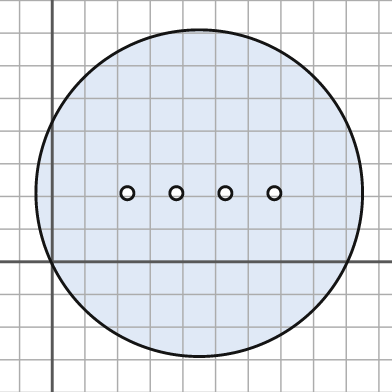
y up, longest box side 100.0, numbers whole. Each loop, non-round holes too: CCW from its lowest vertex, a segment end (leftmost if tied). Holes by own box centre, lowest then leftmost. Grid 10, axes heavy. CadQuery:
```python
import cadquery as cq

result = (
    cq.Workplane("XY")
    .moveTo(45.0, 21.0)
    .circle(50.0)
    .moveTo(23.0, 21.0)
    .circle(2.0)
    .moveTo(38.0, 21.0)
    .circle(2.0)
    .moveTo(53.0, 21.0)
    .circle(2.0)
    .moveTo(68.0, 21.0)
    .circle(2.0)
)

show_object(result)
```